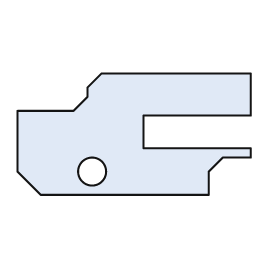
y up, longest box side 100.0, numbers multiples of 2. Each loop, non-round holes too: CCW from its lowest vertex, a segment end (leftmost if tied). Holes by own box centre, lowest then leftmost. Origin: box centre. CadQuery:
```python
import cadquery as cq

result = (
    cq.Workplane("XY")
    .moveTo(-40.0, -26.0)
    .lineTo(32.0, -26.0)
    .lineTo(32.0, -16.0)
    .lineTo(38.0, -10.0)
    .lineTo(50.0, -10.0)
    .lineTo(50.0, -6.0)
    .lineTo(4.0, -6.0)
    .lineTo(4.0, 8.0)
    .lineTo(50.0, 8.0)
    .lineTo(50.0, 26.0)
    .lineTo(-14.0, 26.0)
    .lineTo(-20.0, 20.0)
    .lineTo(-20.0, 16.0)
    .lineTo(-26.0, 10.0)
    .lineTo(-50.0, 10.0)
    .lineTo(-50.0, -16.0)
    .close()
    .moveTo(-18.0, -16.0)
    .circle(6.0)
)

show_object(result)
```